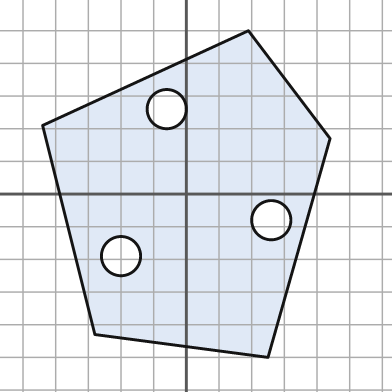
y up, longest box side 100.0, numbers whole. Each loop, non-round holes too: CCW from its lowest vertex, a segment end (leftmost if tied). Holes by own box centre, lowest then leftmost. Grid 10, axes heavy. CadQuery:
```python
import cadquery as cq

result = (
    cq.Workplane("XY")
    .moveTo(25.0, -50.0)
    .lineTo(44.0, 17.0)
    .lineTo(19.0, 50.0)
    .lineTo(-44.0, 21.0)
    .lineTo(-28.0, -43.0)
    .close()
    .moveTo(-20.0, -19.0)
    .circle(6.0)
    .moveTo(26.0, -8.0)
    .circle(6.0)
    .moveTo(-6.0, 26.0)
    .circle(6.0)
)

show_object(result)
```